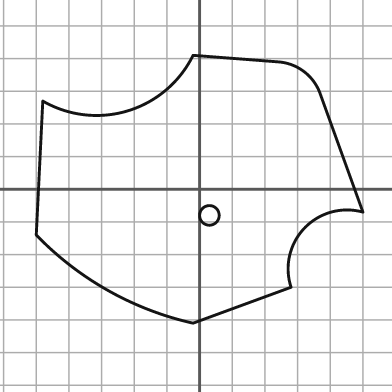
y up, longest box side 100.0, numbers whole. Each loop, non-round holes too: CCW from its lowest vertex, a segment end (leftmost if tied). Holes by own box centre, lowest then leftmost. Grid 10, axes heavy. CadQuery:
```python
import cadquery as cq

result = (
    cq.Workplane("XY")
    .moveTo(-2.0, -41.0)
    .lineTo(28.0, -30.0)
    .threePointArc((32.0, -12.0), (50.0, -7.0))
    .lineTo(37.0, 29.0)
    .threePointArc((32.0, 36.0), (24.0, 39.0))
    .lineTo(-2.0, 41.0)
    .threePointArc((-22.0, 24.0), (-48.0, 27.0))
    .lineTo(-50.0, -14.0)
    .threePointArc((-28.0, -31.0), (-2.0, -41.0))
    .close()
    .moveTo(3.0, -8.0)
    .circle(3.0)
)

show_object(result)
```